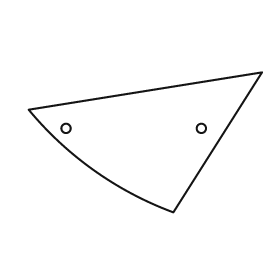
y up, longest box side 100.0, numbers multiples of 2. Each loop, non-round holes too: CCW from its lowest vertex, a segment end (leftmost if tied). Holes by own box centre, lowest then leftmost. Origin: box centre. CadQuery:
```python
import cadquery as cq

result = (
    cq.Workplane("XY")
    .moveTo(12.0, -30.0)
    .lineTo(50.0, 30.0)
    .lineTo(-50.0, 14.0)
    .threePointArc((-22.0, -12.0), (12.0, -30.0))
    .close()
    .moveTo(-34.0, 6.0)
    .circle(2.0)
    .moveTo(24.0, 6.0)
    .circle(2.0)
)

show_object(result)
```